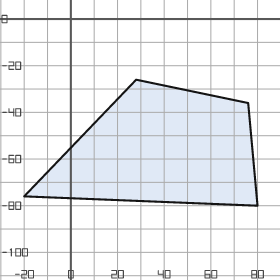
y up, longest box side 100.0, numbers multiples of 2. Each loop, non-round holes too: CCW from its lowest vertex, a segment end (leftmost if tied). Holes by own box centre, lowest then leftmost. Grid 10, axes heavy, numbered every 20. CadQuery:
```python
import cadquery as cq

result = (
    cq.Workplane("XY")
    .moveTo(80.0, -80.0)
    .lineTo(76.0, -36.0)
    .lineTo(28.0, -26.0)
    .lineTo(-20.0, -76.0)
    .close()
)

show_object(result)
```